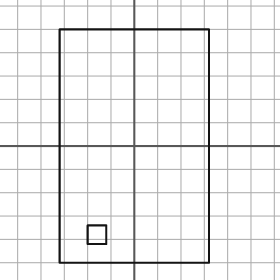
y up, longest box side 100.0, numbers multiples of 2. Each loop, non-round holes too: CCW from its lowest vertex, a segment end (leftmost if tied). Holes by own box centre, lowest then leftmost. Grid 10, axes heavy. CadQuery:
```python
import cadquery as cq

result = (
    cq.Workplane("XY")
    .moveTo(-32.0, -50.0)
    .lineTo(32.0, -50.0)
    .lineTo(32.0, 50.0)
    .lineTo(-32.0, 50.0)
    .close()
    .moveTo(-20.0, -42.0)
    .lineTo(-12.0, -42.0)
    .lineTo(-12.0, -34.0)
    .lineTo(-20.0, -34.0)
    .close()
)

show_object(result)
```